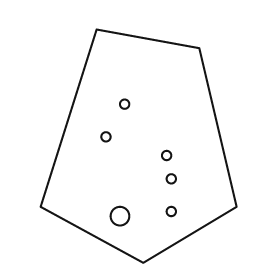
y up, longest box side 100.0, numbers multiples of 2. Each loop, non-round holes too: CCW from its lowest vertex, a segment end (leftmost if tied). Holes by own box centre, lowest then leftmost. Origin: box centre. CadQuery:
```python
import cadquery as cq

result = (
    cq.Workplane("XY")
    .moveTo(2.0, -50.0)
    .lineTo(42.0, -26.0)
    .lineTo(26.0, 42.0)
    .lineTo(-18.0, 50.0)
    .lineTo(-42.0, -26.0)
    .close()
    .moveTo(-8.0, -30.0)
    .circle(4.0)
    .moveTo(14.0, -28.0)
    .circle(2.0)
    .moveTo(14.0, -14.0)
    .circle(2.0)
    .moveTo(12.0, -4.0)
    .circle(2.0)
    .moveTo(-14.0, 4.0)
    .circle(2.0)
    .moveTo(-6.0, 18.0)
    .circle(2.0)
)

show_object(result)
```